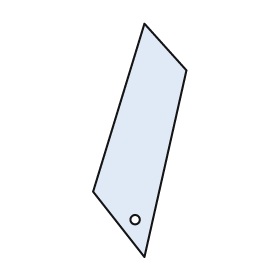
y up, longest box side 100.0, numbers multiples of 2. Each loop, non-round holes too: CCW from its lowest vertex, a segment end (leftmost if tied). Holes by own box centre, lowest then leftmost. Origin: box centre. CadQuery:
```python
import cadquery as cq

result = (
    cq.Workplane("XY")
    .moveTo(2.0, -50.0)
    .lineTo(20.0, 30.0)
    .lineTo(2.0, 50.0)
    .lineTo(-20.0, -22.0)
    .close()
    .moveTo(-2.0, -34.0)
    .circle(2.0)
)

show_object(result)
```